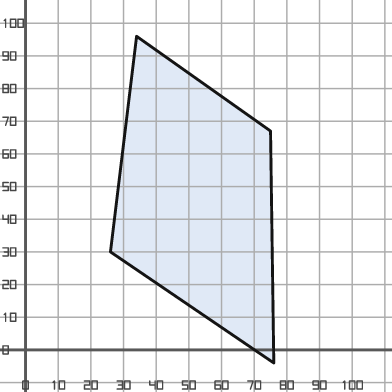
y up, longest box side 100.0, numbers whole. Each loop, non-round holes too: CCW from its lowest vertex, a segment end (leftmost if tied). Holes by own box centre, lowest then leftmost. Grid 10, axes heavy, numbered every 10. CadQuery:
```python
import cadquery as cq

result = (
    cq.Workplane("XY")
    .moveTo(76.0, -4.0)
    .lineTo(75.0, 67.0)
    .lineTo(34.0, 96.0)
    .lineTo(26.0, 30.0)
    .close()
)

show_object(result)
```